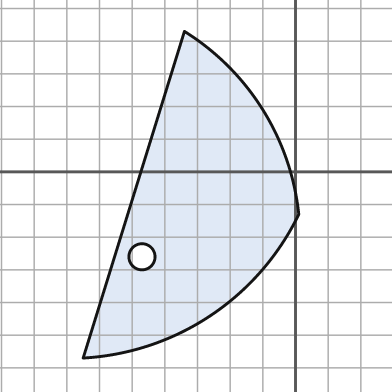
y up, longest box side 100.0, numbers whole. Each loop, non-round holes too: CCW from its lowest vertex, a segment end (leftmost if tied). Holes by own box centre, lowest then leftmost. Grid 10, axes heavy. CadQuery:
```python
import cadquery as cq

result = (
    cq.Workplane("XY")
    .moveTo(-65.0, -57.0)
    .threePointArc((-26.0, -44.0), (1.0, -13.0))
    .threePointArc((-10.0, 19.0), (-34.0, 43.0))
    .close()
    .moveTo(-47.0, -26.0)
    .circle(4.0)
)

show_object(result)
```